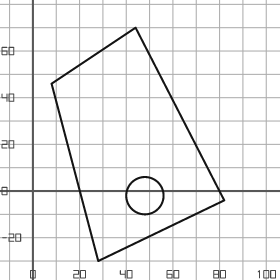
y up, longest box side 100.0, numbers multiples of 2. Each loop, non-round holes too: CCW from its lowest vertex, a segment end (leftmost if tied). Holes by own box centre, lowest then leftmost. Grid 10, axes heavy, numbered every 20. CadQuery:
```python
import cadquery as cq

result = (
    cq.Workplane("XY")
    .moveTo(28.0, -30.0)
    .lineTo(82.0, -4.0)
    .lineTo(44.0, 70.0)
    .lineTo(8.0, 46.0)
    .close()
    .moveTo(48.0, -2.0)
    .circle(8.0)
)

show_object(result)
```